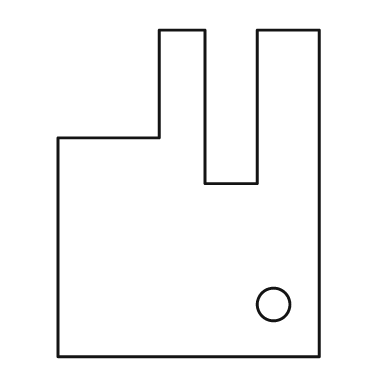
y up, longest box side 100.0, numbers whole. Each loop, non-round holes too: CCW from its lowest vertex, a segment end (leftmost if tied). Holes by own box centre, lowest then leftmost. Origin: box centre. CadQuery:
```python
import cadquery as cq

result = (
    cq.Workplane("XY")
    .moveTo(-40.0, -50.0)
    .lineTo(40.0, -50.0)
    .lineTo(40.0, 50.0)
    .lineTo(21.0, 50.0)
    .lineTo(21.0, 3.0)
    .lineTo(5.0, 3.0)
    .lineTo(5.0, 50.0)
    .lineTo(-9.0, 50.0)
    .lineTo(-9.0, 17.0)
    .lineTo(-40.0, 17.0)
    .close()
    .moveTo(26.0, -34.0)
    .circle(5.0)
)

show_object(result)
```